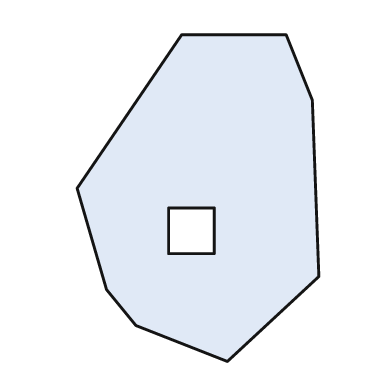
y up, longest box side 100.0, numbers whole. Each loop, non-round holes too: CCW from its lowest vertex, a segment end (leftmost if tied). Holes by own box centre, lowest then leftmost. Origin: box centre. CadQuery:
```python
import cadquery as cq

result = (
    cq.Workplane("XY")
    .moveTo(9.0, -50.0)
    .lineTo(37.0, -24.0)
    .lineTo(35.0, 30.0)
    .lineTo(27.0, 50.0)
    .lineTo(-5.0, 50.0)
    .lineTo(-37.0, 3.0)
    .lineTo(-28.0, -28.0)
    .lineTo(-19.0, -39.0)
    .close()
    .moveTo(-9.0, -17.0)
    .lineTo(5.0, -17.0)
    .lineTo(5.0, -3.0)
    .lineTo(-9.0, -3.0)
    .close()
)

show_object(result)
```